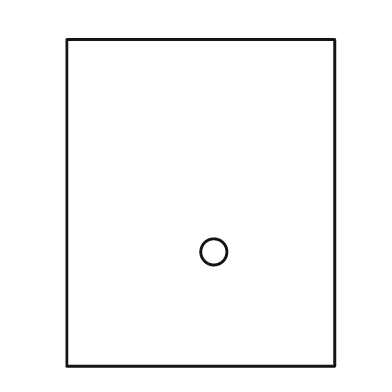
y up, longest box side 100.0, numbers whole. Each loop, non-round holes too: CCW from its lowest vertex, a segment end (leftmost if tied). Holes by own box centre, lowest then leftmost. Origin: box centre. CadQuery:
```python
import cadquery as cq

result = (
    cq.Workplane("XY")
    .moveTo(-41.0, -50.0)
    .lineTo(41.0, -50.0)
    .lineTo(41.0, 50.0)
    .lineTo(-41.0, 50.0)
    .close()
    .moveTo(4.0, -15.0)
    .circle(4.0)
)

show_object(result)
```